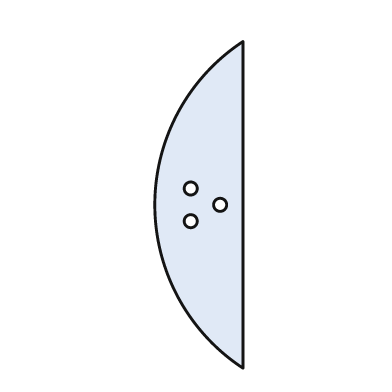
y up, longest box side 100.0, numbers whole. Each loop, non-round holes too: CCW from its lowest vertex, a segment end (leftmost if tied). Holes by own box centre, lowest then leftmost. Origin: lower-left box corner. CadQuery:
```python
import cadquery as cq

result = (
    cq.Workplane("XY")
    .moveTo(27.0, 0.0)
    .lineTo(27.0, 100.0)
    .threePointArc((0.0, 50.0), (27.0, 0.0))
    .close()
    .moveTo(11.0, 45.0)
    .circle(2.0)
    .moveTo(20.0, 50.0)
    .circle(2.0)
    .moveTo(11.0, 55.0)
    .circle(2.0)
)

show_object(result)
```